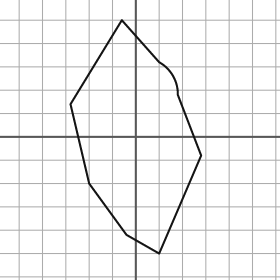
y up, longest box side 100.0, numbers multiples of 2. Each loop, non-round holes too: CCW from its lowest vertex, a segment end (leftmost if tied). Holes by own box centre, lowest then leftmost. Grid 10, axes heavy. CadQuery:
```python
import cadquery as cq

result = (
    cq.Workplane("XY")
    .moveTo(10.0, -50.0)
    .lineTo(28.0, -8.0)
    .lineTo(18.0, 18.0)
    .threePointArc((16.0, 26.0), (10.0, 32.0))
    .lineTo(-6.0, 50.0)
    .lineTo(-28.0, 14.0)
    .lineTo(-20.0, -20.0)
    .lineTo(-4.0, -42.0)
    .close()
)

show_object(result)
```